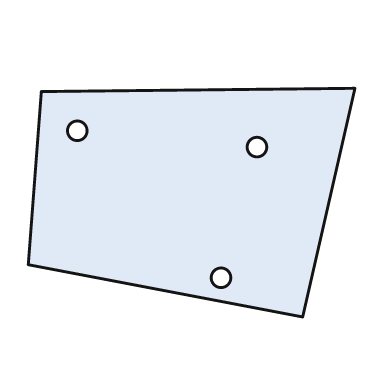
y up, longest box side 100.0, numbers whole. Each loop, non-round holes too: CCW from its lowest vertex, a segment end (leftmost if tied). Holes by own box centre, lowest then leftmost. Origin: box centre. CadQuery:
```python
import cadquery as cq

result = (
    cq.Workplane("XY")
    .moveTo(34.0, -35.0)
    .lineTo(50.0, 35.0)
    .lineTo(-46.0, 34.0)
    .lineTo(-50.0, -19.0)
    .close()
    .moveTo(9.0, -23.0)
    .circle(3.0)
    .moveTo(20.0, 17.0)
    .circle(3.0)
    .moveTo(-35.0, 22.0)
    .circle(3.0)
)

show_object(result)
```